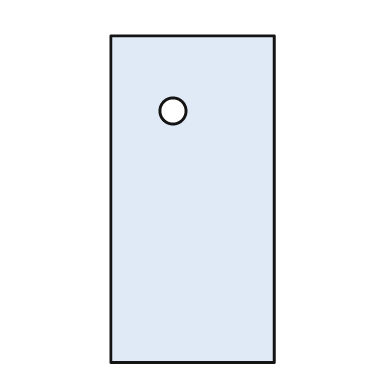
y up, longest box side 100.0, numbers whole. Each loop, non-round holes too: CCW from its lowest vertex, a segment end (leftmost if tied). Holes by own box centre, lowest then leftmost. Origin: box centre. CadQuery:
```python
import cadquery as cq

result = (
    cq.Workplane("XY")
    .moveTo(-25.0, -50.0)
    .lineTo(25.0, -50.0)
    .lineTo(25.0, 50.0)
    .lineTo(-25.0, 50.0)
    .close()
    .moveTo(-6.0, 27.0)
    .circle(4.0)
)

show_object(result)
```